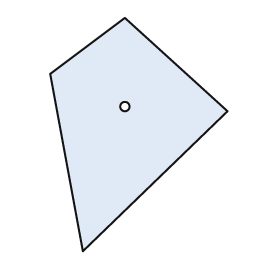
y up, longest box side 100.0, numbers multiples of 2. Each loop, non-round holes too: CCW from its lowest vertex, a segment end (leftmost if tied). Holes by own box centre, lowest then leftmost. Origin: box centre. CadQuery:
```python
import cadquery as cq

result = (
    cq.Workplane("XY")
    .moveTo(-24.0, -50.0)
    .lineTo(38.0, 10.0)
    .lineTo(-6.0, 50.0)
    .lineTo(-38.0, 26.0)
    .close()
    .moveTo(-6.0, 12.0)
    .circle(2.0)
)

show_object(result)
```